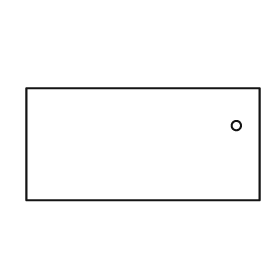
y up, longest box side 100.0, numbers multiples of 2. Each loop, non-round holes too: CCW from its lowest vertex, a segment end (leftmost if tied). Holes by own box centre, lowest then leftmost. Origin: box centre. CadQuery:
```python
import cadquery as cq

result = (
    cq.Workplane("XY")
    .moveTo(-50.0, -24.0)
    .lineTo(50.0, -24.0)
    .lineTo(50.0, 24.0)
    .lineTo(-50.0, 24.0)
    .close()
    .moveTo(40.0, 8.0)
    .circle(2.0)
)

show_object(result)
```